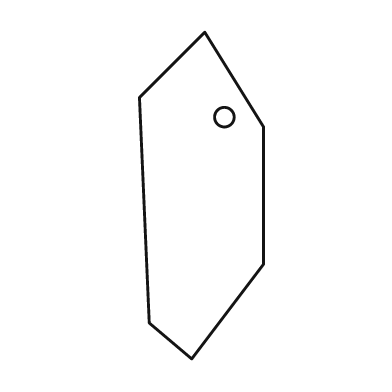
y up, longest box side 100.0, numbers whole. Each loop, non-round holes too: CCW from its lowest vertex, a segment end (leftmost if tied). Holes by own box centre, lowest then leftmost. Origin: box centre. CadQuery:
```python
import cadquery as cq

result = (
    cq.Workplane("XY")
    .moveTo(-3.0, -50.0)
    .lineTo(19.0, -21.0)
    .lineTo(19.0, 21.0)
    .lineTo(1.0, 50.0)
    .lineTo(-19.0, 30.0)
    .lineTo(-16.0, -39.0)
    .close()
    .moveTo(7.0, 24.0)
    .circle(3.0)
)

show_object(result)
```